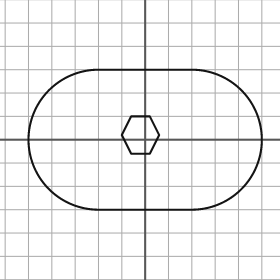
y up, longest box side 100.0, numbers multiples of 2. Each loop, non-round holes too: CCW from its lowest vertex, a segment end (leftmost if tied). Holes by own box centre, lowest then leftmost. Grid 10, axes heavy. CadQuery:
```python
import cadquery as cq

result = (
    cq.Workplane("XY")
    .moveTo(-20.0, -30.0)
    .lineTo(20.0, -30.0)
    .threePointArc((50.0, 0.0), (20.0, 30.0))
    .lineTo(-20.0, 30.0)
    .threePointArc((-50.0, 0.0), (-20.0, -30.0))
    .close()
    .moveTo(-6.0, -6.0)
    .lineTo(2.0, -6.0)
    .lineTo(6.0, 2.0)
    .lineTo(2.0, 10.0)
    .lineTo(-6.0, 10.0)
    .lineTo(-10.0, 2.0)
    .close()
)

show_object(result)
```